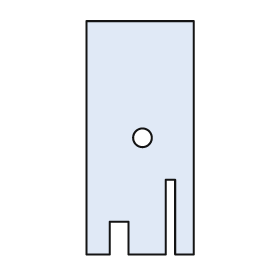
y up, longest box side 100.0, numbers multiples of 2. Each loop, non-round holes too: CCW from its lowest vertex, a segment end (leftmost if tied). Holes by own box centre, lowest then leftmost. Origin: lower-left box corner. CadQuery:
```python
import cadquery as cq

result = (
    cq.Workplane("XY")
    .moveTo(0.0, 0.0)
    .lineTo(10.0, 0.0)
    .lineTo(10.0, 14.0)
    .lineTo(18.0, 14.0)
    .lineTo(18.0, 0.0)
    .lineTo(34.0, 0.0)
    .lineTo(34.0, 32.0)
    .lineTo(38.0, 32.0)
    .lineTo(38.0, 0.0)
    .lineTo(46.0, 0.0)
    .lineTo(46.0, 100.0)
    .lineTo(0.0, 100.0)
    .close()
    .moveTo(24.0, 50.0)
    .circle(4.0)
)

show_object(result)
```